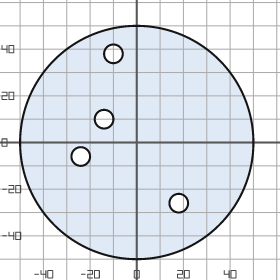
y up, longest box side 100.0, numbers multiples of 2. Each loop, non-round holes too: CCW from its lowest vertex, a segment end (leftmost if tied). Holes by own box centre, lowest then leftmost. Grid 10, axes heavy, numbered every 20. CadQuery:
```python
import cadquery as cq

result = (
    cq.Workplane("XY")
    .moveTo(0.0, 0.0)
    .circle(50.0)
    .moveTo(18.0, -26.0)
    .circle(4.0)
    .moveTo(-24.0, -6.0)
    .circle(4.0)
    .moveTo(-14.0, 10.0)
    .circle(4.0)
    .moveTo(-10.0, 38.0)
    .circle(4.0)
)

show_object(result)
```